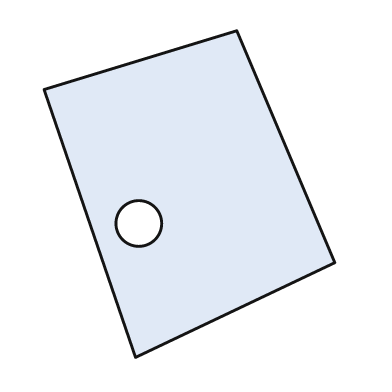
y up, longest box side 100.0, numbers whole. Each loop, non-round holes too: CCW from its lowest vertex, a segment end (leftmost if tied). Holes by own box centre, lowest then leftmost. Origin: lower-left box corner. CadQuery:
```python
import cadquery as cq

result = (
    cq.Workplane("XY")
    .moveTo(28.0, 0.0)
    .lineTo(89.0, 29.0)
    .lineTo(59.0, 100.0)
    .lineTo(0.0, 82.0)
    .close()
    .moveTo(29.0, 41.0)
    .circle(7.0)
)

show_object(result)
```